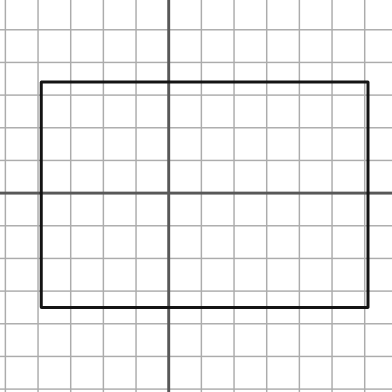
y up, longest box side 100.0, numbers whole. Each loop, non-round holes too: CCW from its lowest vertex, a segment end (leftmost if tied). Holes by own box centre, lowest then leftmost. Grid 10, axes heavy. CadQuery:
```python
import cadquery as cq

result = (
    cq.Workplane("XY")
    .moveTo(-39.0, -35.0)
    .lineTo(61.0, -35.0)
    .lineTo(61.0, 34.0)
    .lineTo(-39.0, 34.0)
    .close()
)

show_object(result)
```